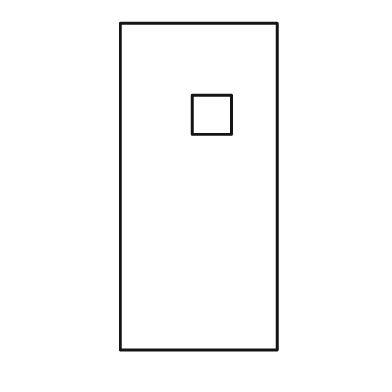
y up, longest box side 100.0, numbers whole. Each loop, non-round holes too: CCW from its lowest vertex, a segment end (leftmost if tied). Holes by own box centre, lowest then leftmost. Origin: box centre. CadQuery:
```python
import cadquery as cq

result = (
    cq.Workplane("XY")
    .moveTo(-24.0, -50.0)
    .lineTo(24.0, -50.0)
    .lineTo(24.0, 50.0)
    .lineTo(-24.0, 50.0)
    .close()
    .moveTo(-2.0, 16.0)
    .lineTo(10.0, 16.0)
    .lineTo(10.0, 28.0)
    .lineTo(-2.0, 28.0)
    .close()
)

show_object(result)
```